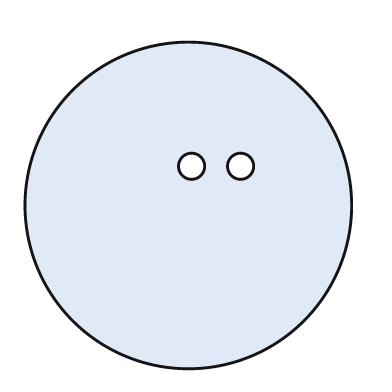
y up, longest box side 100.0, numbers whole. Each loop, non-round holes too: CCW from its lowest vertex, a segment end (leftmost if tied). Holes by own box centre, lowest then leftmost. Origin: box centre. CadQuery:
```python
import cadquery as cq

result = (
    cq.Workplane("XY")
    .moveTo(0.0, 0.0)
    .circle(50.0)
    .moveTo(1.0, 12.0)
    .circle(4.0)
    .moveTo(16.0, 12.0)
    .circle(4.0)
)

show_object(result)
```